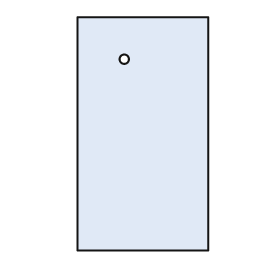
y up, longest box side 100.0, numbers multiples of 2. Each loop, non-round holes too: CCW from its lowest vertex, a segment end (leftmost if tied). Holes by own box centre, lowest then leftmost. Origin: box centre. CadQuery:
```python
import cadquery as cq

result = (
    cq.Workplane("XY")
    .moveTo(-28.0, -50.0)
    .lineTo(28.0, -50.0)
    .lineTo(28.0, 50.0)
    .lineTo(-28.0, 50.0)
    .close()
    .moveTo(-8.0, 32.0)
    .circle(2.0)
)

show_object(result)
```